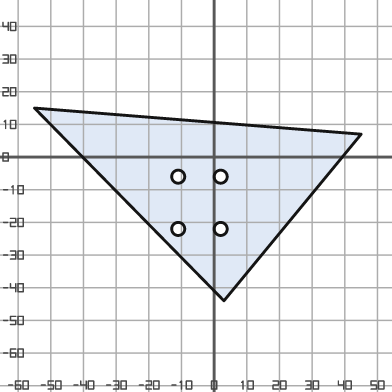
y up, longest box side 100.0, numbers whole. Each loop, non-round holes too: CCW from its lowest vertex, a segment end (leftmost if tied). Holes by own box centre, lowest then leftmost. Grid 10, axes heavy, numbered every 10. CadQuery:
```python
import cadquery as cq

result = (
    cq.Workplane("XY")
    .moveTo(3.0, -44.0)
    .lineTo(45.0, 7.0)
    .lineTo(-55.0, 15.0)
    .close()
    .moveTo(-11.0, -22.0)
    .circle(2.0)
    .moveTo(2.0, -22.0)
    .circle(2.0)
    .moveTo(-11.0, -6.0)
    .circle(2.0)
    .moveTo(2.0, -6.0)
    .circle(2.0)
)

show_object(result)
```